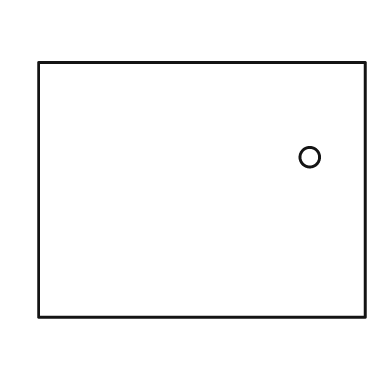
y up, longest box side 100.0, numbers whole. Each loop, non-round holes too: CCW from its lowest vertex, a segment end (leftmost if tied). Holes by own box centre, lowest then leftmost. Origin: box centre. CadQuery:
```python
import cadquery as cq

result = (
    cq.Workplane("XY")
    .moveTo(-50.0, -39.0)
    .lineTo(50.0, -39.0)
    .lineTo(50.0, 39.0)
    .lineTo(-50.0, 39.0)
    .close()
    .moveTo(33.0, 10.0)
    .circle(3.0)
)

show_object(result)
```